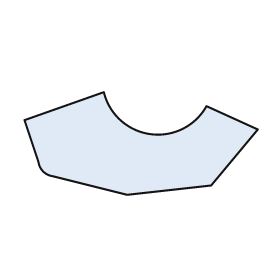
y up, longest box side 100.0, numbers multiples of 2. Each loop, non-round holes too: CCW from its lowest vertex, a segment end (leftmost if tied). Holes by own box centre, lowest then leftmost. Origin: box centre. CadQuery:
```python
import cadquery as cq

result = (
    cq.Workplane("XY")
    .moveTo(-6.0, -22.0)
    .lineTo(30.0, -18.0)
    .lineTo(50.0, 6.0)
    .lineTo(28.0, 16.0)
    .threePointArc((4.0, 4.0), (-16.0, 22.0))
    .lineTo(-50.0, 10.0)
    .lineTo(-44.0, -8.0)
    .threePointArc((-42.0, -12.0), (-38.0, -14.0))
    .close()
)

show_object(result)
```